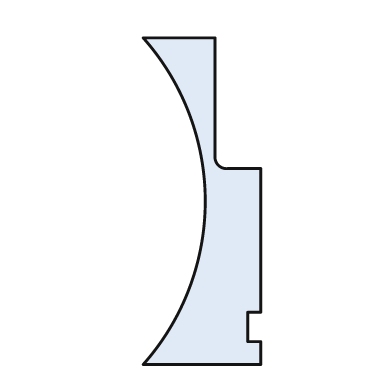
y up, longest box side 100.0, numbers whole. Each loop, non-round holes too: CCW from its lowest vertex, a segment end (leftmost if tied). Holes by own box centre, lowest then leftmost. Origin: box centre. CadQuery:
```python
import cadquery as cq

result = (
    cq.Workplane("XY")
    .moveTo(-18.0, -50.0)
    .lineTo(18.0, -50.0)
    .lineTo(18.0, -43.0)
    .lineTo(14.0, -43.0)
    .lineTo(14.0, -34.0)
    .lineTo(18.0, -34.0)
    .lineTo(18.0, 10.0)
    .lineTo(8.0, 10.0)
    .threePointArc((5.0, 11.0), (4.0, 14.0))
    .lineTo(4.0, 50.0)
    .lineTo(-18.0, 50.0)
    .threePointArc((1.0, 0.0), (-18.0, -50.0))
    .close()
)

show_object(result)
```